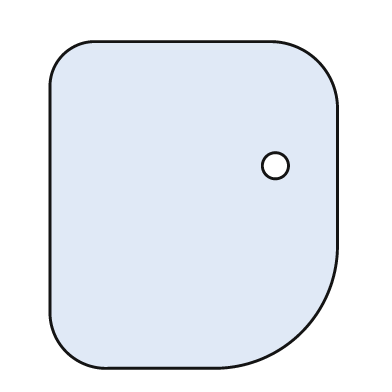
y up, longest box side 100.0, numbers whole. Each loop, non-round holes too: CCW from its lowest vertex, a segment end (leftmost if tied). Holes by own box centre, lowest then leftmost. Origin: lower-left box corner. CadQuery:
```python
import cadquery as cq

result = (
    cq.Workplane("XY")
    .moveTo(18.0, 0.0)
    .lineTo(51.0, 0.0)
    .threePointArc((77.0, 11.0), (88.0, 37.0))
    .lineTo(88.0, 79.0)
    .threePointArc((82.0, 94.0), (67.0, 100.0))
    .lineTo(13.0, 100.0)
    .threePointArc((4.0, 96.0), (0.0, 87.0))
    .lineTo(0.0, 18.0)
    .threePointArc((5.0, 5.0), (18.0, 0.0))
    .close()
    .moveTo(69.0, 62.0)
    .circle(4.0)
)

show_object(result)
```